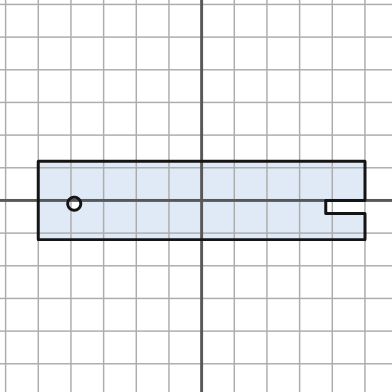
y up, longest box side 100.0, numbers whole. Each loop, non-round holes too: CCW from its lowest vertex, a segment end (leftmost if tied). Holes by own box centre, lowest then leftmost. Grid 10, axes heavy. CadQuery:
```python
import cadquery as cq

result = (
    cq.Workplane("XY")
    .moveTo(-50.0, -12.0)
    .lineTo(50.0, -12.0)
    .lineTo(50.0, -4.0)
    .lineTo(38.0, -4.0)
    .lineTo(38.0, 0.0)
    .lineTo(50.0, 0.0)
    .lineTo(50.0, 12.0)
    .lineTo(-50.0, 12.0)
    .close()
    .moveTo(-39.0, -1.0)
    .circle(2.0)
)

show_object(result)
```